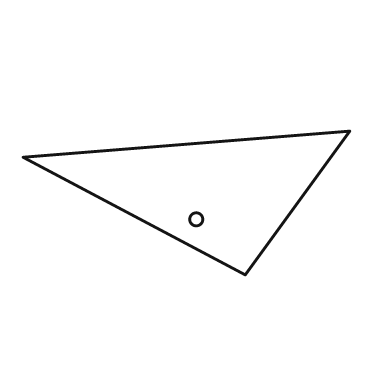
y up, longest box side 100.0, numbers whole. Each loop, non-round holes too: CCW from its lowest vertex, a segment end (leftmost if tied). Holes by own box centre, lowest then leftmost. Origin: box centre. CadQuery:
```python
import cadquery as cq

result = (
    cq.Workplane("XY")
    .moveTo(18.0, -22.0)
    .lineTo(50.0, 22.0)
    .lineTo(-50.0, 14.0)
    .close()
    .moveTo(3.0, -5.0)
    .circle(2.0)
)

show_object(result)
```